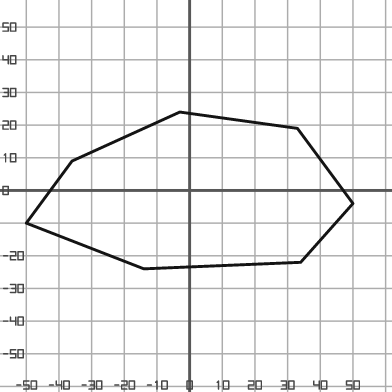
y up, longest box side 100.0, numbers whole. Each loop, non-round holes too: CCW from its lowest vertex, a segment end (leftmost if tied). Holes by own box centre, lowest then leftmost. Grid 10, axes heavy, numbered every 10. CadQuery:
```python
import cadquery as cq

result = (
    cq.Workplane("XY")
    .moveTo(-14.0, -24.0)
    .lineTo(34.0, -22.0)
    .lineTo(50.0, -4.0)
    .lineTo(33.0, 19.0)
    .lineTo(-3.0, 24.0)
    .lineTo(-36.0, 9.0)
    .lineTo(-50.0, -10.0)
    .close()
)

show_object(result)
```